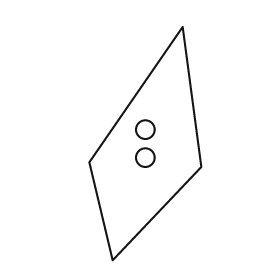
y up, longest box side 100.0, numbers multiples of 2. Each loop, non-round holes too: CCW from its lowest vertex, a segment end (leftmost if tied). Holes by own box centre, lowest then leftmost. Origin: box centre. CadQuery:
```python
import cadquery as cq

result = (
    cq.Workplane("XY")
    .moveTo(-14.0, -50.0)
    .lineTo(24.0, -10.0)
    .lineTo(16.0, 50.0)
    .lineTo(-24.0, -8.0)
    .close()
    .moveTo(0.0, -6.0)
    .circle(4.0)
    .moveTo(0.0, 6.0)
    .circle(4.0)
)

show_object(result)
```